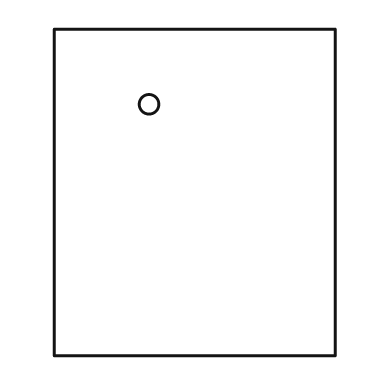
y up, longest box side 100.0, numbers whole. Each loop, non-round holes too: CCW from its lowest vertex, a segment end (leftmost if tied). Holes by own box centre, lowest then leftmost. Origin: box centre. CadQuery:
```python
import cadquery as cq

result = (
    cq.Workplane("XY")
    .moveTo(-43.0, -50.0)
    .lineTo(43.0, -50.0)
    .lineTo(43.0, 50.0)
    .lineTo(-43.0, 50.0)
    .close()
    .moveTo(-14.0, 27.0)
    .circle(3.0)
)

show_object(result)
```